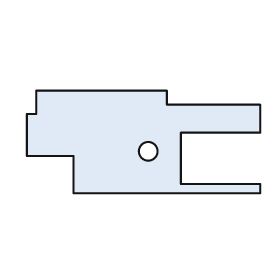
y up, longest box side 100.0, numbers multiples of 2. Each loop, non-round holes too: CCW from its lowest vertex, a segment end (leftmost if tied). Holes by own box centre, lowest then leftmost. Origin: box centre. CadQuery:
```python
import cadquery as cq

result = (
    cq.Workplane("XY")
    .moveTo(-30.0, -22.0)
    .lineTo(50.0, -22.0)
    .lineTo(50.0, -18.0)
    .lineTo(16.0, -18.0)
    .lineTo(16.0, 4.0)
    .lineTo(50.0, 4.0)
    .lineTo(50.0, 16.0)
    .lineTo(10.0, 16.0)
    .lineTo(10.0, 22.0)
    .lineTo(-46.0, 22.0)
    .lineTo(-46.0, 12.0)
    .lineTo(-50.0, 12.0)
    .lineTo(-50.0, -6.0)
    .lineTo(-30.0, -6.0)
    .close()
    .moveTo(2.0, -4.0)
    .circle(4.0)
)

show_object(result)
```